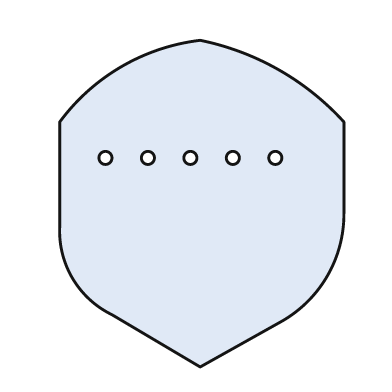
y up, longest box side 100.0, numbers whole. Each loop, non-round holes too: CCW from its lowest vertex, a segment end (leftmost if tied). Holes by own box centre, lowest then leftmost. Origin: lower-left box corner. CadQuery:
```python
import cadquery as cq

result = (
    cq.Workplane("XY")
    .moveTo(43.0, 0.0)
    .lineTo(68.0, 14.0)
    .threePointArc((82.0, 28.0), (87.0, 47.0))
    .lineTo(87.0, 75.0)
    .threePointArc((67.0, 91.0), (43.0, 100.0))
    .threePointArc((19.0, 92.0), (0.0, 75.0))
    .lineTo(0.0, 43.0)
    .threePointArc((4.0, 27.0), (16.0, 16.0))
    .close()
    .moveTo(14.0, 64.0)
    .circle(2.0)
    .moveTo(27.0, 64.0)
    .circle(2.0)
    .moveTo(40.0, 64.0)
    .circle(2.0)
    .moveTo(53.0, 64.0)
    .circle(2.0)
    .moveTo(66.0, 64.0)
    .circle(2.0)
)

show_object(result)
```